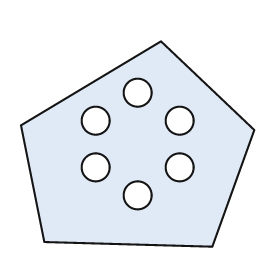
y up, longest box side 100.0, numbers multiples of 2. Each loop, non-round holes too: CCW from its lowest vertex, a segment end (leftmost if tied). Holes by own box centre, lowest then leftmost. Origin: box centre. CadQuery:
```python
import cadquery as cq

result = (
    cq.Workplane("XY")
    .moveTo(32.0, -44.0)
    .lineTo(50.0, 6.0)
    .lineTo(10.0, 44.0)
    .lineTo(-50.0, 8.0)
    .lineTo(-40.0, -42.0)
    .close()
    .moveTo(0.0, -22.0)
    .circle(6.0)
    .moveTo(-18.0, -10.0)
    .circle(6.0)
    .moveTo(18.0, -10.0)
    .circle(6.0)
    .moveTo(-18.0, 10.0)
    .circle(6.0)
    .moveTo(18.0, 10.0)
    .circle(6.0)
    .moveTo(0.0, 22.0)
    .circle(6.0)
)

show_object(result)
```